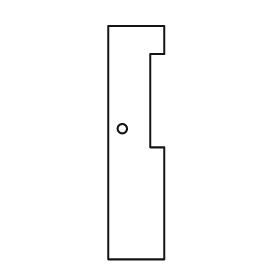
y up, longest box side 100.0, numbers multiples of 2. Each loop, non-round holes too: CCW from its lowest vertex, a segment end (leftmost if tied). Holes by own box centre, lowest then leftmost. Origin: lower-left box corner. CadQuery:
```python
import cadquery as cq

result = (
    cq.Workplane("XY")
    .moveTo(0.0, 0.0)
    .lineTo(24.0, 0.0)
    .lineTo(24.0, 48.0)
    .lineTo(18.0, 48.0)
    .lineTo(18.0, 88.0)
    .lineTo(24.0, 88.0)
    .lineTo(24.0, 100.0)
    .lineTo(0.0, 100.0)
    .close()
    .moveTo(6.0, 56.0)
    .circle(2.0)
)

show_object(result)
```